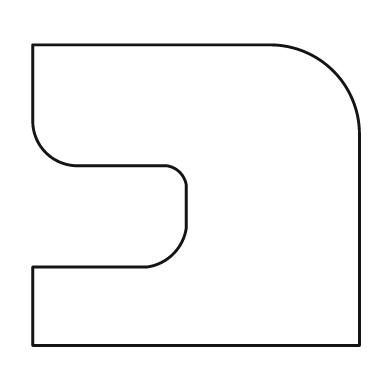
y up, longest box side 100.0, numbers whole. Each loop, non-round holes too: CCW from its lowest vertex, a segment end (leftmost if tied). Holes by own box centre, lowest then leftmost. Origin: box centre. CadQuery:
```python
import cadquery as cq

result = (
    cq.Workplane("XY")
    .moveTo(-50.0, -46.0)
    .lineTo(50.0, -46.0)
    .lineTo(50.0, 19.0)
    .threePointArc((42.0, 38.0), (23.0, 46.0))
    .lineTo(-50.0, 46.0)
    .lineTo(-50.0, 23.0)
    .threePointArc((-46.0, 13.0), (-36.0, 9.0))
    .lineTo(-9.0, 9.0)
    .threePointArc((-5.0, 7.0), (-3.0, 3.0))
    .lineTo(-3.0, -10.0)
    .threePointArc((-7.0, -18.0), (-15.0, -22.0))
    .lineTo(-50.0, -22.0)
    .close()
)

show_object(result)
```